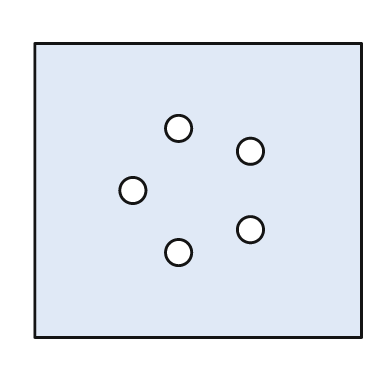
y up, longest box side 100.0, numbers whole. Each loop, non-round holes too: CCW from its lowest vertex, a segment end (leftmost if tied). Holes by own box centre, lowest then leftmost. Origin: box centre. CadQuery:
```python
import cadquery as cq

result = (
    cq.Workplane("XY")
    .moveTo(-50.0, -45.0)
    .lineTo(50.0, -45.0)
    .lineTo(50.0, 45.0)
    .lineTo(-50.0, 45.0)
    .close()
    .moveTo(-6.0, -19.0)
    .circle(4.0)
    .moveTo(16.0, -12.0)
    .circle(4.0)
    .moveTo(-20.0, 0.0)
    .circle(4.0)
    .moveTo(16.0, 12.0)
    .circle(4.0)
    .moveTo(-6.0, 19.0)
    .circle(4.0)
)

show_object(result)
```